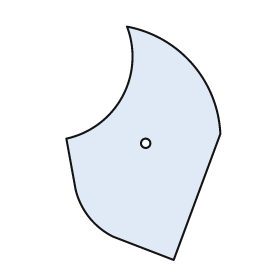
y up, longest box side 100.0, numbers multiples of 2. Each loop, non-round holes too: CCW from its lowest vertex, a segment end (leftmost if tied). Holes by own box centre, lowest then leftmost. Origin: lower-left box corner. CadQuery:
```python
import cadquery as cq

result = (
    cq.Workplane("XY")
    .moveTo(46.0, 0.0)
    .lineTo(66.0, 54.0)
    .threePointArc((54.0, 84.0), (26.0, 100.0))
    .threePointArc((24.0, 70.0), (0.0, 52.0))
    .lineTo(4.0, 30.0)
    .threePointArc((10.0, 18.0), (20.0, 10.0))
    .close()
    .moveTo(34.0, 50.0)
    .circle(2.0)
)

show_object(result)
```